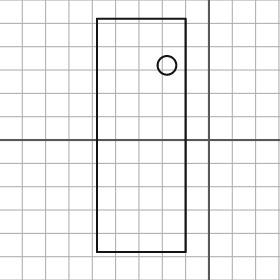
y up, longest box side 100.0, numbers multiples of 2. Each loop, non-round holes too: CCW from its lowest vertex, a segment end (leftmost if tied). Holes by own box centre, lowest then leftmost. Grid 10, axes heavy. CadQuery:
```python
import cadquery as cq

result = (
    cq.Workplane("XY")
    .moveTo(-48.0, -48.0)
    .lineTo(-10.0, -48.0)
    .lineTo(-10.0, 52.0)
    .lineTo(-48.0, 52.0)
    .close()
    .moveTo(-18.0, 32.0)
    .circle(4.0)
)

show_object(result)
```